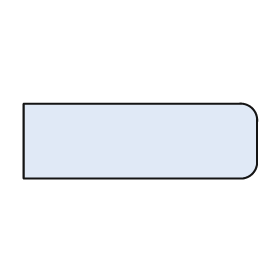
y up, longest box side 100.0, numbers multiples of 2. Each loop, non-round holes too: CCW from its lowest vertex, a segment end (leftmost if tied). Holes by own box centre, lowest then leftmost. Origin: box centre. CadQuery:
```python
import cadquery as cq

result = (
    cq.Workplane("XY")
    .moveTo(-50.0, -16.0)
    .lineTo(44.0, -16.0)
    .threePointArc((48.0, -14.0), (50.0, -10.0))
    .lineTo(50.0, 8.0)
    .threePointArc((48.0, 14.0), (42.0, 16.0))
    .lineTo(-50.0, 16.0)
    .close()
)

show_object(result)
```